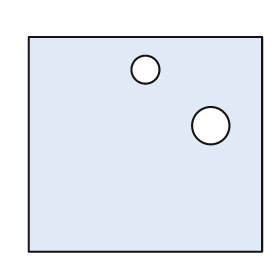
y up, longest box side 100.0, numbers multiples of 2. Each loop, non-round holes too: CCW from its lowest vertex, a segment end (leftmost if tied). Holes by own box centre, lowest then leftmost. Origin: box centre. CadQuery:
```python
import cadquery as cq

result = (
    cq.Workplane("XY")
    .moveTo(-50.0, -46.0)
    .lineTo(50.0, -46.0)
    .lineTo(50.0, 46.0)
    .lineTo(-50.0, 46.0)
    .close()
    .moveTo(28.0, 8.0)
    .circle(8.0)
    .moveTo(0.0, 32.0)
    .circle(6.0)
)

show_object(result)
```